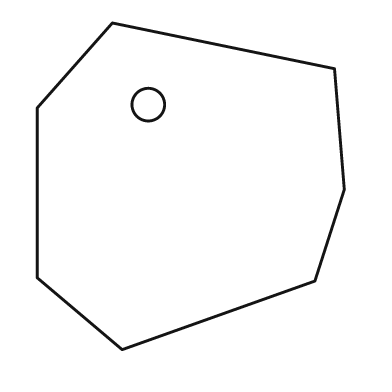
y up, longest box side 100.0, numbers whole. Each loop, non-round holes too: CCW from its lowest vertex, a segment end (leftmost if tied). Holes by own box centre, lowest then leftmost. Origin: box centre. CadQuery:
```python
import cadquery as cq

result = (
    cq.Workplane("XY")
    .moveTo(-21.0, -50.0)
    .lineTo(38.0, -29.0)
    .lineTo(47.0, -1.0)
    .lineTo(44.0, 36.0)
    .lineTo(-24.0, 50.0)
    .lineTo(-47.0, 24.0)
    .lineTo(-47.0, -28.0)
    .close()
    .moveTo(-13.0, 25.0)
    .circle(5.0)
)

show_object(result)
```